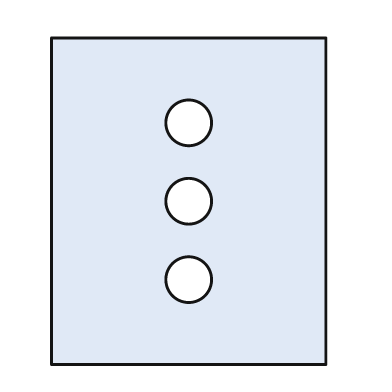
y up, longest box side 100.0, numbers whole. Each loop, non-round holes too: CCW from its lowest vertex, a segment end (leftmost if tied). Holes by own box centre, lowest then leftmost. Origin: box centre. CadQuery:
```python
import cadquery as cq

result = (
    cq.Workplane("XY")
    .moveTo(-42.0, -50.0)
    .lineTo(42.0, -50.0)
    .lineTo(42.0, 50.0)
    .lineTo(-42.0, 50.0)
    .close()
    .moveTo(0.0, -24.0)
    .circle(7.0)
    .moveTo(0.0, 0.0)
    .circle(7.0)
    .moveTo(0.0, 24.0)
    .circle(7.0)
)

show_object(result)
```